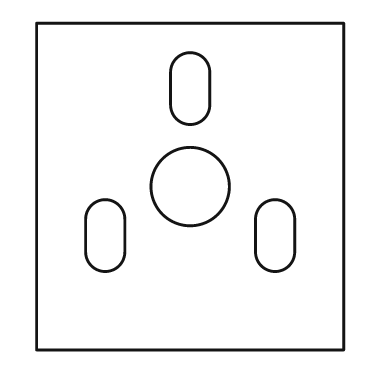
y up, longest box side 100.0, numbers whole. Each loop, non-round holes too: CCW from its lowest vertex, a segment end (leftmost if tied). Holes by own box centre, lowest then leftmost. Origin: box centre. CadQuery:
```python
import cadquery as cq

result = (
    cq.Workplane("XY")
    .moveTo(-47.0, -50.0)
    .lineTo(47.0, -50.0)
    .lineTo(47.0, 50.0)
    .lineTo(-47.0, 50.0)
    .close()
    .moveTo(-32.0, -20.0)
    .threePointArc((-26.0, -26.0), (-20.0, -20.0))
    .lineTo(-20.0, -10.0)
    .threePointArc((-26.0, -4.0), (-32.0, -10.0))
    .close()
    .moveTo(20.0, -20.0)
    .threePointArc((26.0, -26.0), (32.0, -20.0))
    .lineTo(32.0, -10.0)
    .threePointArc((26.0, -4.0), (20.0, -10.0))
    .close()
    .moveTo(0.0, 0.0)
    .circle(12.0)
    .moveTo(-6.0, 25.0)
    .threePointArc((0.0, 19.0), (6.0, 25.0))
    .lineTo(6.0, 35.0)
    .threePointArc((0.0, 41.0), (-6.0, 35.0))
    .close()
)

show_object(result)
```